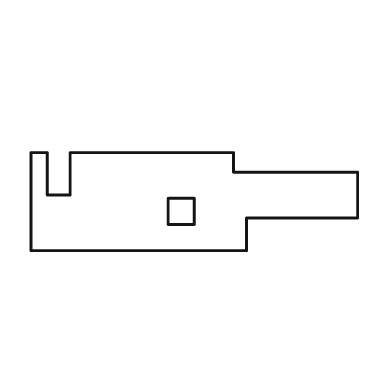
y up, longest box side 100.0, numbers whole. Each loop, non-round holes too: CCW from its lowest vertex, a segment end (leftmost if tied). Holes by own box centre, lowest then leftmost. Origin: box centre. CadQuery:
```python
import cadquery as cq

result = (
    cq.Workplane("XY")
    .moveTo(-50.0, -15.0)
    .lineTo(16.0, -15.0)
    .lineTo(16.0, -5.0)
    .lineTo(50.0, -5.0)
    .lineTo(50.0, 9.0)
    .lineTo(12.0, 9.0)
    .lineTo(12.0, 15.0)
    .lineTo(-38.0, 15.0)
    .lineTo(-38.0, 2.0)
    .lineTo(-45.0, 2.0)
    .lineTo(-45.0, 15.0)
    .lineTo(-50.0, 15.0)
    .close()
    .moveTo(-8.0, -7.0)
    .lineTo(0.0, -7.0)
    .lineTo(0.0, 1.0)
    .lineTo(-8.0, 1.0)
    .close()
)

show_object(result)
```